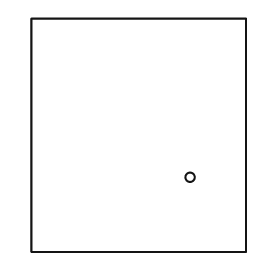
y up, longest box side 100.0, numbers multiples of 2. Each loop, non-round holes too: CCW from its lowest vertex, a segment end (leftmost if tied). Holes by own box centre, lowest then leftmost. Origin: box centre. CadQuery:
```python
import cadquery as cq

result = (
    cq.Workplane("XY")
    .moveTo(-46.0, -50.0)
    .lineTo(46.0, -50.0)
    .lineTo(46.0, 50.0)
    .lineTo(-46.0, 50.0)
    .close()
    .moveTo(22.0, -18.0)
    .circle(2.0)
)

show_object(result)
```